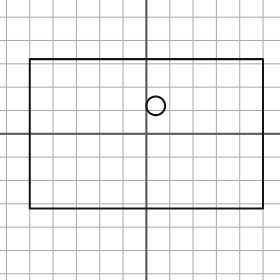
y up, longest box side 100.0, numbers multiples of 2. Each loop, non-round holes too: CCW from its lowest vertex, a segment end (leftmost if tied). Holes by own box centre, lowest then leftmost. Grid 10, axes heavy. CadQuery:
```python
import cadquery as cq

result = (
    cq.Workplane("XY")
    .moveTo(-50.0, -32.0)
    .lineTo(50.0, -32.0)
    .lineTo(50.0, 32.0)
    .lineTo(-50.0, 32.0)
    .close()
    .moveTo(4.0, 12.0)
    .circle(4.0)
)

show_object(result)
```